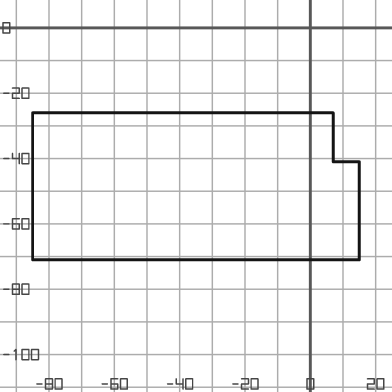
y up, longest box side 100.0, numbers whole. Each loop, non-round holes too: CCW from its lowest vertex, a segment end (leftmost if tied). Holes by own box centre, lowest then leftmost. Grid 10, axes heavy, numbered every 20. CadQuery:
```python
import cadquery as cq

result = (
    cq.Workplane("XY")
    .moveTo(-85.0, -71.0)
    .lineTo(15.0, -71.0)
    .lineTo(15.0, -41.0)
    .lineTo(7.0, -41.0)
    .lineTo(7.0, -26.0)
    .lineTo(-85.0, -26.0)
    .close()
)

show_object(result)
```